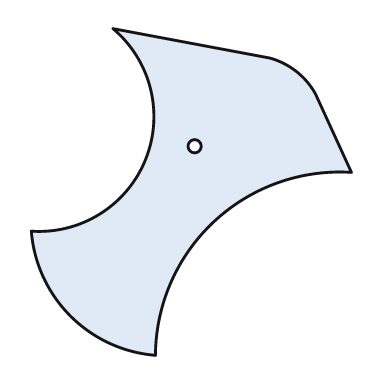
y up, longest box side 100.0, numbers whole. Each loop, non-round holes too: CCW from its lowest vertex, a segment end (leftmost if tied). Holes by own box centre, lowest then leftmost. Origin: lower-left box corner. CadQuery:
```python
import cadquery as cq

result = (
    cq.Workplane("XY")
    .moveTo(38.0, 0.0)
    .threePointArc((56.0, 41.0), (98.0, 56.0))
    .lineTo(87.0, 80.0)
    .threePointArc((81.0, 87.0), (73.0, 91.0))
    .lineTo(25.0, 100.0)
    .threePointArc((35.0, 60.0), (0.0, 38.0))
    .threePointArc((12.0, 12.0), (38.0, 0.0))
    .close()
    .moveTo(50.0, 64.0)
    .circle(2.0)
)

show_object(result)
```